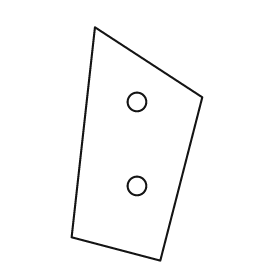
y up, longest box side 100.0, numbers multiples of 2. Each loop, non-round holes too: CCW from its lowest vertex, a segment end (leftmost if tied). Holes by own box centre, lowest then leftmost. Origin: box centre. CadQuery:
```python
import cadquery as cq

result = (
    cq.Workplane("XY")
    .moveTo(10.0, -50.0)
    .lineTo(28.0, 20.0)
    .lineTo(-18.0, 50.0)
    .lineTo(-28.0, -40.0)
    .close()
    .moveTo(0.0, -18.0)
    .circle(4.0)
    .moveTo(0.0, 18.0)
    .circle(4.0)
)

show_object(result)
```